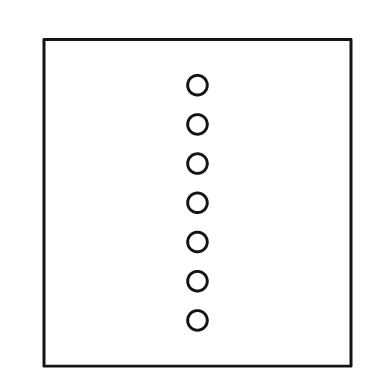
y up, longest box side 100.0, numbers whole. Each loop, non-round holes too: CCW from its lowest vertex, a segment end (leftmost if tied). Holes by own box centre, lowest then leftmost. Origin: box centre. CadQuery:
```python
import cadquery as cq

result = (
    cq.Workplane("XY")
    .moveTo(-47.0, -50.0)
    .lineTo(47.0, -50.0)
    .lineTo(47.0, 50.0)
    .lineTo(-47.0, 50.0)
    .close()
    .moveTo(0.0, -36.0)
    .circle(3.0)
    .moveTo(0.0, -24.0)
    .circle(3.0)
    .moveTo(0.0, -12.0)
    .circle(3.0)
    .moveTo(0.0, 0.0)
    .circle(3.0)
    .moveTo(0.0, 12.0)
    .circle(3.0)
    .moveTo(0.0, 24.0)
    .circle(3.0)
    .moveTo(0.0, 36.0)
    .circle(3.0)
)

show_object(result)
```